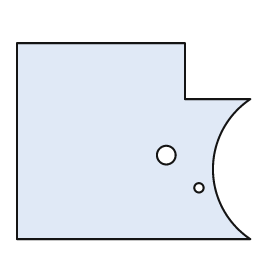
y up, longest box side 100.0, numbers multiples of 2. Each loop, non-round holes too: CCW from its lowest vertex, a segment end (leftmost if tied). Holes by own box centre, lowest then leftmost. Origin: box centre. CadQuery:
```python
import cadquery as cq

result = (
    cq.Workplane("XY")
    .moveTo(-50.0, -42.0)
    .lineTo(50.0, -42.0)
    .threePointArc((34.0, -12.0), (50.0, 18.0))
    .lineTo(22.0, 18.0)
    .lineTo(22.0, 42.0)
    .lineTo(-50.0, 42.0)
    .close()
    .moveTo(28.0, -20.0)
    .circle(2.0)
    .moveTo(14.0, -6.0)
    .circle(4.0)
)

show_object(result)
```